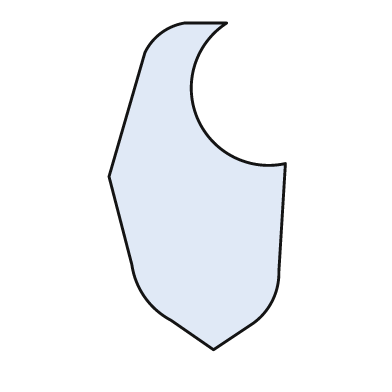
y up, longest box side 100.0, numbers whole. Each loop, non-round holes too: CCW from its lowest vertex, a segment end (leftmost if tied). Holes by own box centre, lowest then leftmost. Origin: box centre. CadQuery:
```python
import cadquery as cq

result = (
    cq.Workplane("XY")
    .moveTo(5.0, -50.0)
    .lineTo(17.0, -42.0)
    .threePointArc((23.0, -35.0), (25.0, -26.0))
    .lineTo(27.0, 7.0)
    .threePointArc((0.0, 21.0), (9.0, 50.0))
    .lineTo(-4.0, 50.0)
    .threePointArc((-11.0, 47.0), (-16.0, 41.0))
    .lineTo(-27.0, 3.0)
    .lineTo(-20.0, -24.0)
    .threePointArc((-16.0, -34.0), (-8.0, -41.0))
    .close()
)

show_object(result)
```